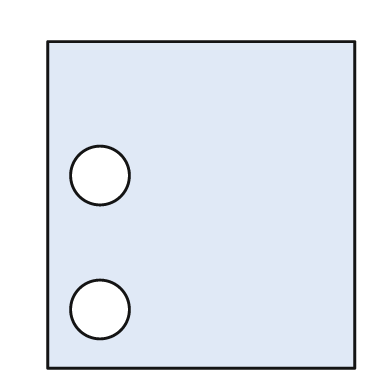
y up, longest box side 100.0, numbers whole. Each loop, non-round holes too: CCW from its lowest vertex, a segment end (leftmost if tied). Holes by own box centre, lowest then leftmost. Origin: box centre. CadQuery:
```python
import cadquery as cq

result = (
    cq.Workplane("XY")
    .moveTo(-47.0, -50.0)
    .lineTo(47.0, -50.0)
    .lineTo(47.0, 50.0)
    .lineTo(-47.0, 50.0)
    .close()
    .moveTo(-31.0, -32.0)
    .circle(9.0)
    .moveTo(-31.0, 9.0)
    .circle(9.0)
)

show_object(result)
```